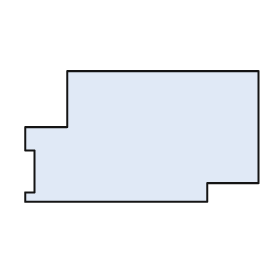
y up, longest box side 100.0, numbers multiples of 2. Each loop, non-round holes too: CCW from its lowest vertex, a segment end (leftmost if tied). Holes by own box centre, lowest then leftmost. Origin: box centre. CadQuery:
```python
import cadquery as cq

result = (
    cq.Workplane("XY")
    .moveTo(-50.0, -28.0)
    .lineTo(28.0, -28.0)
    .lineTo(28.0, -20.0)
    .lineTo(50.0, -20.0)
    .lineTo(50.0, 28.0)
    .lineTo(-32.0, 28.0)
    .lineTo(-32.0, 4.0)
    .lineTo(-50.0, 4.0)
    .lineTo(-50.0, -6.0)
    .lineTo(-46.0, -6.0)
    .lineTo(-46.0, -24.0)
    .lineTo(-50.0, -24.0)
    .close()
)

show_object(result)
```